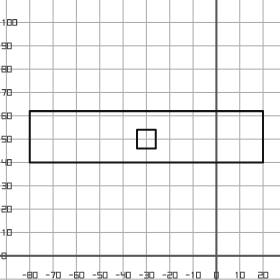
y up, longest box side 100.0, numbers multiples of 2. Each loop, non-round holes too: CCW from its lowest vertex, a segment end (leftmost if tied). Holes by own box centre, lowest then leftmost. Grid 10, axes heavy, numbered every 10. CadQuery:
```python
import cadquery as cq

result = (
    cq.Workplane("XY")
    .moveTo(-80.0, 40.0)
    .lineTo(20.0, 40.0)
    .lineTo(20.0, 62.0)
    .lineTo(-80.0, 62.0)
    .close()
    .moveTo(-34.0, 46.0)
    .lineTo(-26.0, 46.0)
    .lineTo(-26.0, 54.0)
    .lineTo(-34.0, 54.0)
    .close()
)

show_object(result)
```